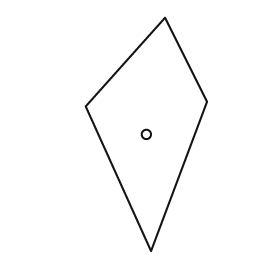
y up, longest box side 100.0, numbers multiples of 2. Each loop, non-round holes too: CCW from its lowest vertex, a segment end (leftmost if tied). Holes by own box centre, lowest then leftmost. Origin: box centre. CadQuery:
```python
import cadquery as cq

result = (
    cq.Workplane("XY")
    .moveTo(2.0, -50.0)
    .lineTo(26.0, 14.0)
    .lineTo(8.0, 50.0)
    .lineTo(-26.0, 12.0)
    .close()
    .moveTo(0.0, 0.0)
    .circle(2.0)
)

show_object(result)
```